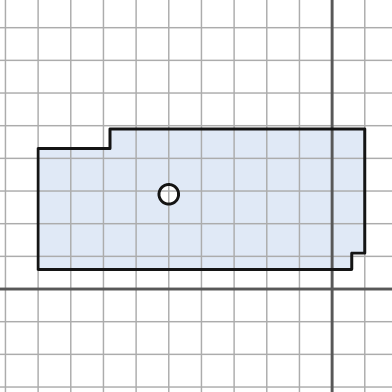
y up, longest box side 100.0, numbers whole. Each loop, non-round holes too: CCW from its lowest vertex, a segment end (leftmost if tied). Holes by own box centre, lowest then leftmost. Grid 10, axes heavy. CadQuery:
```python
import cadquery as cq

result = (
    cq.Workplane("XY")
    .moveTo(-90.0, 6.0)
    .lineTo(6.0, 6.0)
    .lineTo(6.0, 11.0)
    .lineTo(10.0, 11.0)
    .lineTo(10.0, 49.0)
    .lineTo(-68.0, 49.0)
    .lineTo(-68.0, 43.0)
    .lineTo(-90.0, 43.0)
    .close()
    .moveTo(-50.0, 29.0)
    .circle(3.0)
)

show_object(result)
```